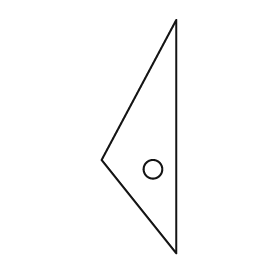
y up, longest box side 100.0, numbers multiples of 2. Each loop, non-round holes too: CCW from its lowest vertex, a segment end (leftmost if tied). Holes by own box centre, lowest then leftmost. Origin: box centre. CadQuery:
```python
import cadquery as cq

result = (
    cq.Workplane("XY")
    .moveTo(16.0, -50.0)
    .lineTo(16.0, 50.0)
    .lineTo(-16.0, -10.0)
    .close()
    .moveTo(6.0, -14.0)
    .circle(4.0)
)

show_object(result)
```